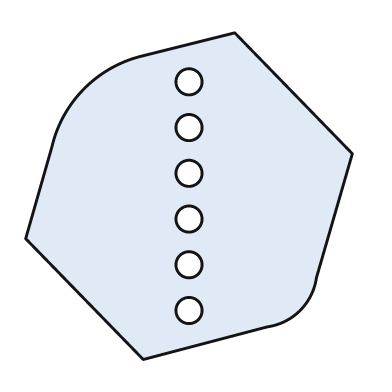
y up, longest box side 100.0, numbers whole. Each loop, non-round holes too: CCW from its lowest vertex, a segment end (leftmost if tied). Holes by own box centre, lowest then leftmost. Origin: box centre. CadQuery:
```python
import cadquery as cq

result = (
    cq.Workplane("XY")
    .moveTo(-14.0, -50.0)
    .lineTo(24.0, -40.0)
    .threePointArc((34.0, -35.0), (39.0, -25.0))
    .lineTo(50.0, 13.0)
    .lineTo(14.0, 50.0)
    .lineTo(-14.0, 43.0)
    .threePointArc((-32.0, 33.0), (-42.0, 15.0))
    .lineTo(-50.0, -13.0)
    .close()
    .moveTo(0.0, -35.0)
    .circle(4.0)
    .moveTo(0.0, -21.0)
    .circle(4.0)
    .moveTo(0.0, -7.0)
    .circle(4.0)
    .moveTo(0.0, 7.0)
    .circle(4.0)
    .moveTo(0.0, 21.0)
    .circle(4.0)
    .moveTo(0.0, 35.0)
    .circle(4.0)
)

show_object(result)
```